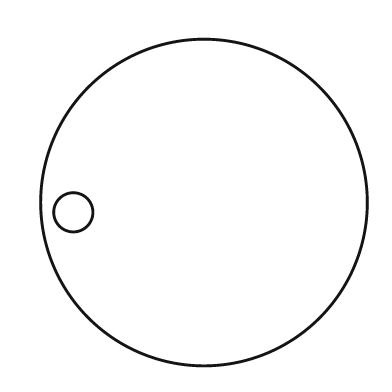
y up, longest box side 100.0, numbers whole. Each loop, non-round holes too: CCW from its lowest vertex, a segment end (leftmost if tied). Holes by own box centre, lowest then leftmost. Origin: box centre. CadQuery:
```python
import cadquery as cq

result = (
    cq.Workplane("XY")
    .moveTo(0.0, 0.0)
    .circle(50.0)
    .moveTo(-40.0, -3.0)
    .circle(6.0)
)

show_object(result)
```